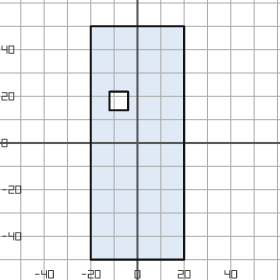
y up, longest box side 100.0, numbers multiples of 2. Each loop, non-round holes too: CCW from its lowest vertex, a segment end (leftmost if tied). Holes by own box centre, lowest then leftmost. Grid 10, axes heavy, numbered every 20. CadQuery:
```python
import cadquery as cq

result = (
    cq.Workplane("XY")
    .moveTo(-20.0, -50.0)
    .lineTo(20.0, -50.0)
    .lineTo(20.0, 50.0)
    .lineTo(-20.0, 50.0)
    .close()
    .moveTo(-12.0, 14.0)
    .lineTo(-4.0, 14.0)
    .lineTo(-4.0, 22.0)
    .lineTo(-12.0, 22.0)
    .close()
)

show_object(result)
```